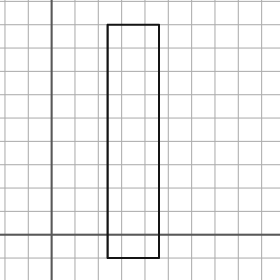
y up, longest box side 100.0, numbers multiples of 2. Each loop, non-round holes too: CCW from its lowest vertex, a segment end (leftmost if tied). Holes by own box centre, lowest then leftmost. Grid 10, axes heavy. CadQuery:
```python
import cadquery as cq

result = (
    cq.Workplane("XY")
    .moveTo(24.0, -10.0)
    .lineTo(46.0, -10.0)
    .lineTo(46.0, 90.0)
    .lineTo(24.0, 90.0)
    .close()
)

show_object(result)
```